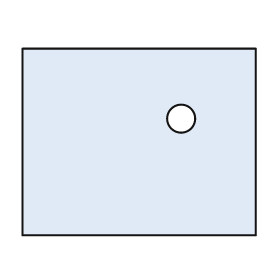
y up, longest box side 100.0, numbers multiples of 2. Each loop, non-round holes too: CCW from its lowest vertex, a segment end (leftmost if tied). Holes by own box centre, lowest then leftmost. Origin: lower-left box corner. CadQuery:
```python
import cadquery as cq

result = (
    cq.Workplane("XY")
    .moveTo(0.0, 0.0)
    .lineTo(100.0, 0.0)
    .lineTo(100.0, 80.0)
    .lineTo(0.0, 80.0)
    .close()
    .moveTo(68.0, 50.0)
    .circle(6.0)
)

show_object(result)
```